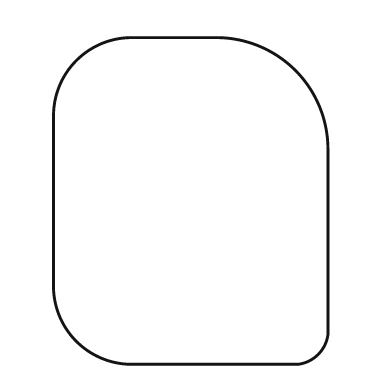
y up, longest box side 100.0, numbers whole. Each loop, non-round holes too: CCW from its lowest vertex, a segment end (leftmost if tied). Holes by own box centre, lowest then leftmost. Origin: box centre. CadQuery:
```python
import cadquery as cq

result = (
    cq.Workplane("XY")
    .moveTo(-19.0, -50.0)
    .lineTo(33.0, -50.0)
    .threePointArc((39.0, -47.0), (42.0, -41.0))
    .lineTo(42.0, 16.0)
    .threePointArc((32.0, 40.0), (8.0, 50.0))
    .lineTo(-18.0, 50.0)
    .threePointArc((-35.0, 43.0), (-42.0, 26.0))
    .lineTo(-42.0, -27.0)
    .threePointArc((-35.0, -43.0), (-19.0, -50.0))
    .close()
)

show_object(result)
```